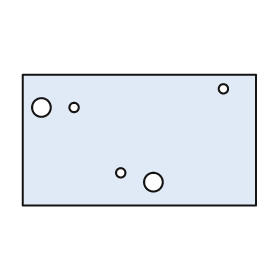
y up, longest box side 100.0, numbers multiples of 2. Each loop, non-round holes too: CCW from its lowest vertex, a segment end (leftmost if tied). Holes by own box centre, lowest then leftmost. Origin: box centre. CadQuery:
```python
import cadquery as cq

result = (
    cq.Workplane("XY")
    .moveTo(-50.0, -28.0)
    .lineTo(50.0, -28.0)
    .lineTo(50.0, 28.0)
    .lineTo(-50.0, 28.0)
    .close()
    .moveTo(6.0, -18.0)
    .circle(4.0)
    .moveTo(-8.0, -14.0)
    .circle(2.0)
    .moveTo(-42.0, 14.0)
    .circle(4.0)
    .moveTo(-28.0, 14.0)
    .circle(2.0)
    .moveTo(36.0, 22.0)
    .circle(2.0)
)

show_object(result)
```